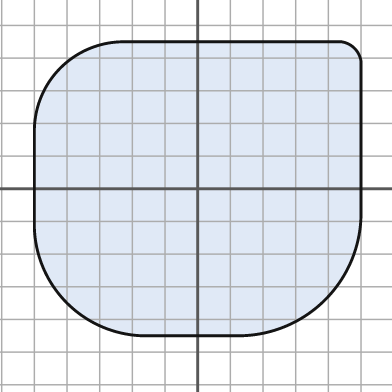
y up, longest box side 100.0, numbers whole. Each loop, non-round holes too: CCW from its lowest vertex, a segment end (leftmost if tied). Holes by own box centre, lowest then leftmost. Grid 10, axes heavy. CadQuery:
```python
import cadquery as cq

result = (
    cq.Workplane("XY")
    .moveTo(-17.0, -45.0)
    .lineTo(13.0, -45.0)
    .threePointArc((39.0, -34.0), (50.0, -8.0))
    .lineTo(50.0, 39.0)
    .threePointArc((48.0, 43.0), (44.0, 45.0))
    .lineTo(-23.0, 45.0)
    .threePointArc((-42.0, 37.0), (-50.0, 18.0))
    .lineTo(-50.0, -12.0)
    .threePointArc((-40.0, -35.0), (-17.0, -45.0))
    .close()
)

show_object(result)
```